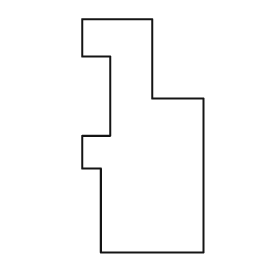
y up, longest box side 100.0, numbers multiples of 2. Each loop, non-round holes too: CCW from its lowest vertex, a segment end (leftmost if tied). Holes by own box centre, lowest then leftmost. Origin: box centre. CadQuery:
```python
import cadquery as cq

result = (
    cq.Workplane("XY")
    .moveTo(-18.0, -50.0)
    .lineTo(26.0, -50.0)
    .lineTo(26.0, 16.0)
    .lineTo(4.0, 16.0)
    .lineTo(4.0, 50.0)
    .lineTo(-26.0, 50.0)
    .lineTo(-26.0, 34.0)
    .lineTo(-14.0, 34.0)
    .lineTo(-14.0, 0.0)
    .lineTo(-26.0, 0.0)
    .lineTo(-26.0, -14.0)
    .lineTo(-18.0, -14.0)
    .close()
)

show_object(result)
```